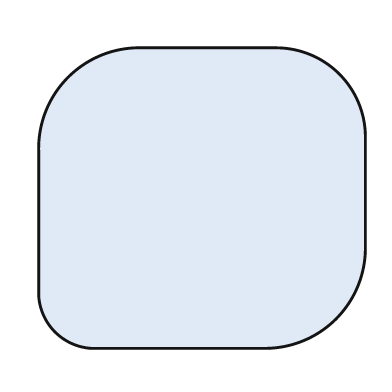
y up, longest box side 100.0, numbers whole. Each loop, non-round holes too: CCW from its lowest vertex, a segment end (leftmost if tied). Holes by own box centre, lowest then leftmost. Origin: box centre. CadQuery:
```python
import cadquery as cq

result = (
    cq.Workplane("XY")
    .moveTo(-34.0, -46.0)
    .lineTo(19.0, -46.0)
    .threePointArc((41.0, -37.0), (50.0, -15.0))
    .lineTo(50.0, 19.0)
    .threePointArc((42.0, 38.0), (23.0, 46.0))
    .lineTo(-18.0, 46.0)
    .threePointArc((-41.0, 37.0), (-50.0, 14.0))
    .lineTo(-50.0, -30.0)
    .threePointArc((-45.0, -41.0), (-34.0, -46.0))
    .close()
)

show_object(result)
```